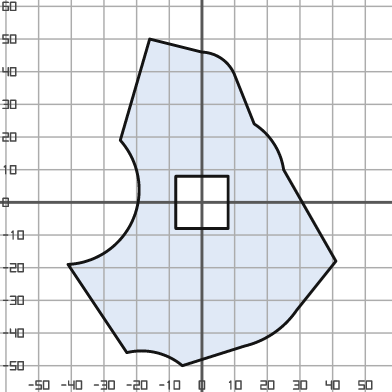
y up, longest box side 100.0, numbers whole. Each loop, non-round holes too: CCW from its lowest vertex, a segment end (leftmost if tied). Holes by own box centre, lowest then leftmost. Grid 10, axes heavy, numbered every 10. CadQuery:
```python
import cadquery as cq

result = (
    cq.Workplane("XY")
    .moveTo(-6.0, -50.0)
    .lineTo(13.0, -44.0)
    .threePointArc((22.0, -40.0), (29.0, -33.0))
    .lineTo(41.0, -18.0)
    .lineTo(25.0, 10.0)
    .threePointArc((22.0, 18.0), (16.0, 24.0))
    .lineTo(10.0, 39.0)
    .threePointArc((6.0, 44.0), (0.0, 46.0))
    .lineTo(-16.0, 50.0)
    .lineTo(-25.0, 19.0)
    .threePointArc((-21.0, -5.0), (-41.0, -19.0))
    .lineTo(-23.0, -46.0)
    .threePointArc((-14.0, -46.0), (-6.0, -50.0))
    .close()
    .moveTo(-8.0, -8.0)
    .lineTo(8.0, -8.0)
    .lineTo(8.0, 8.0)
    .lineTo(-8.0, 8.0)
    .close()
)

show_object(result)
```